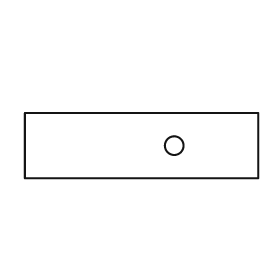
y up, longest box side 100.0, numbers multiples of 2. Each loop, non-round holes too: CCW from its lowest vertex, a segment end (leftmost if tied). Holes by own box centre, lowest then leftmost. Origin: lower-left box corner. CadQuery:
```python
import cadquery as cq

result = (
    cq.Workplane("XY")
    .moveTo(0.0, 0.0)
    .lineTo(100.0, 0.0)
    .lineTo(100.0, 28.0)
    .lineTo(0.0, 28.0)
    .close()
    .moveTo(64.0, 14.0)
    .circle(4.0)
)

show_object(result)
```